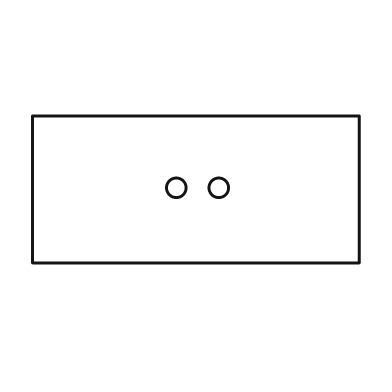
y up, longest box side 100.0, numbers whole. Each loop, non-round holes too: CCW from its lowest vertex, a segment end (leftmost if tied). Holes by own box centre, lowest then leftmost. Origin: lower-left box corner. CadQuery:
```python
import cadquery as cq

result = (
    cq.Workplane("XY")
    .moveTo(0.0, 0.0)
    .lineTo(100.0, 0.0)
    .lineTo(100.0, 45.0)
    .lineTo(0.0, 45.0)
    .close()
    .moveTo(44.0, 23.0)
    .circle(3.0)
    .moveTo(57.0, 23.0)
    .circle(3.0)
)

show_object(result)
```